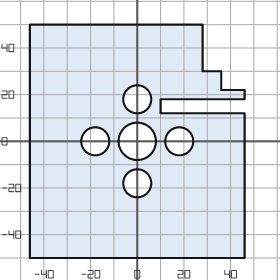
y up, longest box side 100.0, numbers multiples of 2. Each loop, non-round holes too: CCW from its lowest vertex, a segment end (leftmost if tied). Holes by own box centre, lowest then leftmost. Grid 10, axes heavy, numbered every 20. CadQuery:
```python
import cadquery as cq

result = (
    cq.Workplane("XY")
    .moveTo(-46.0, -50.0)
    .lineTo(46.0, -50.0)
    .lineTo(46.0, 12.0)
    .lineTo(10.0, 12.0)
    .lineTo(10.0, 18.0)
    .lineTo(46.0, 18.0)
    .lineTo(46.0, 22.0)
    .lineTo(36.0, 22.0)
    .lineTo(36.0, 30.0)
    .lineTo(28.0, 30.0)
    .lineTo(28.0, 50.0)
    .lineTo(-46.0, 50.0)
    .close()
    .moveTo(0.0, -18.0)
    .circle(6.0)
    .moveTo(-18.0, 0.0)
    .circle(6.0)
    .moveTo(0.0, 0.0)
    .circle(8.0)
    .moveTo(18.0, 0.0)
    .circle(6.0)
    .moveTo(0.0, 18.0)
    .circle(6.0)
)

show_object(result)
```